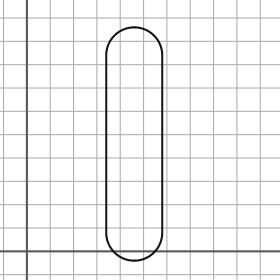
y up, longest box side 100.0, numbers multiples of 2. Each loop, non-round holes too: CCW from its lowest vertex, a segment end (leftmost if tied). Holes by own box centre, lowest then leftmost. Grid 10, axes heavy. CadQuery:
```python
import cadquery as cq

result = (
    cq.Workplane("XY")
    .moveTo(34.0, 8.0)
    .threePointArc((46.0, -4.0), (58.0, 8.0))
    .lineTo(58.0, 84.0)
    .threePointArc((46.0, 96.0), (34.0, 84.0))
    .close()
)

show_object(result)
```